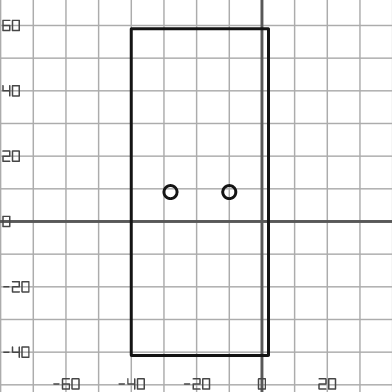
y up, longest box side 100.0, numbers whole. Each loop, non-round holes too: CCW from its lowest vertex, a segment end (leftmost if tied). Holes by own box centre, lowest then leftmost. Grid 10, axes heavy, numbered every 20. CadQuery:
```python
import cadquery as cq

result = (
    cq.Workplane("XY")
    .moveTo(-40.0, -41.0)
    .lineTo(2.0, -41.0)
    .lineTo(2.0, 59.0)
    .lineTo(-40.0, 59.0)
    .close()
    .moveTo(-28.0, 9.0)
    .circle(2.0)
    .moveTo(-10.0, 9.0)
    .circle(2.0)
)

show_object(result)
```